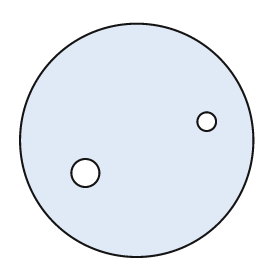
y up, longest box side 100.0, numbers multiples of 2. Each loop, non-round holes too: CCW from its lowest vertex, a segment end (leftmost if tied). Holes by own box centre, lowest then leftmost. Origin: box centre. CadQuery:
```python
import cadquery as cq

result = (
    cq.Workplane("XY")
    .moveTo(0.0, 0.0)
    .circle(50.0)
    .moveTo(-22.0, -14.0)
    .circle(6.0)
    .moveTo(30.0, 8.0)
    .circle(4.0)
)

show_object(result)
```